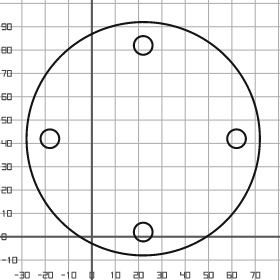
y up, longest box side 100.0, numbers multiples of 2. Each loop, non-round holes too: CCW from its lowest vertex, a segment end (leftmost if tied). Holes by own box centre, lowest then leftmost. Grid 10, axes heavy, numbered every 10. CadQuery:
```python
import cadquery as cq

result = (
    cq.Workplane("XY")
    .moveTo(22.0, 42.0)
    .circle(50.0)
    .moveTo(22.0, 2.0)
    .circle(4.0)
    .moveTo(-18.0, 42.0)
    .circle(4.0)
    .moveTo(62.0, 42.0)
    .circle(4.0)
    .moveTo(22.0, 82.0)
    .circle(4.0)
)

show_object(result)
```